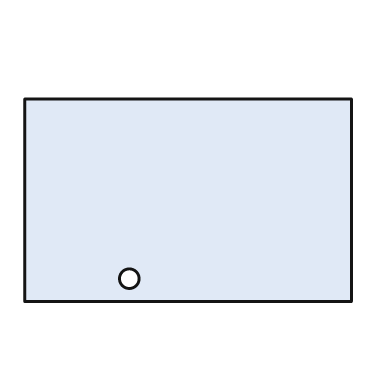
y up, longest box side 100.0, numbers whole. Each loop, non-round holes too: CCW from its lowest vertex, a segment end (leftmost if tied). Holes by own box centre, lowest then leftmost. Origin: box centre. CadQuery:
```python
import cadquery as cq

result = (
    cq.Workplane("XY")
    .moveTo(-50.0, -31.0)
    .lineTo(50.0, -31.0)
    .lineTo(50.0, 31.0)
    .lineTo(-50.0, 31.0)
    .close()
    .moveTo(-18.0, -24.0)
    .circle(3.0)
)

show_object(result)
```